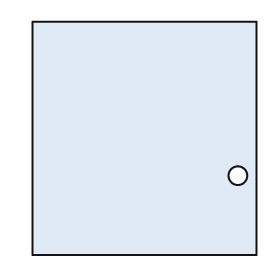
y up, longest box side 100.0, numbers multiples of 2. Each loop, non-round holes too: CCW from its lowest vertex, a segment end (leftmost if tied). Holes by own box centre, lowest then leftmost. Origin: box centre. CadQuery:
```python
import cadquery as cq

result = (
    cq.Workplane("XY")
    .moveTo(-48.0, -50.0)
    .lineTo(48.0, -50.0)
    .lineTo(48.0, 50.0)
    .lineTo(-48.0, 50.0)
    .close()
    .moveTo(40.0, -16.0)
    .circle(4.0)
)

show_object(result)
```